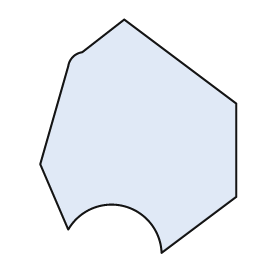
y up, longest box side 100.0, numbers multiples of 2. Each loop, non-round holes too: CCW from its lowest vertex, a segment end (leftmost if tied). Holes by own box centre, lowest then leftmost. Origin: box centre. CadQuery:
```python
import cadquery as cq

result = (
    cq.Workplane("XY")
    .moveTo(10.0, -50.0)
    .lineTo(42.0, -26.0)
    .lineTo(42.0, 14.0)
    .lineTo(-6.0, 50.0)
    .lineTo(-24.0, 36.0)
    .threePointArc((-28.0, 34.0), (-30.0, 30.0))
    .lineTo(-42.0, -12.0)
    .lineTo(-30.0, -40.0)
    .threePointArc((-6.0, -30.0), (10.0, -50.0))
    .close()
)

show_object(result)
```